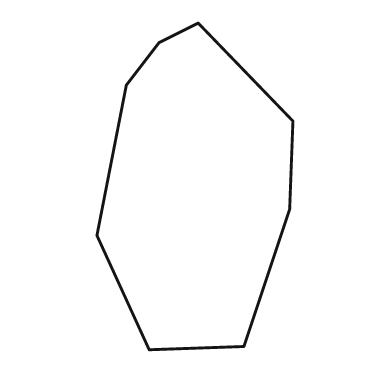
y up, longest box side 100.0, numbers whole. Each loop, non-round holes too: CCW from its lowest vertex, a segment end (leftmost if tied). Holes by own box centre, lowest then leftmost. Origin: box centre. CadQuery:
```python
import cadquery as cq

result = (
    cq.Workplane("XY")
    .moveTo(-14.0, -50.0)
    .lineTo(15.0, -49.0)
    .lineTo(29.0, -7.0)
    .lineTo(30.0, 20.0)
    .lineTo(1.0, 50.0)
    .lineTo(-11.0, 44.0)
    .lineTo(-21.0, 31.0)
    .lineTo(-30.0, -15.0)
    .close()
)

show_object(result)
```